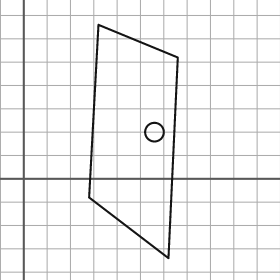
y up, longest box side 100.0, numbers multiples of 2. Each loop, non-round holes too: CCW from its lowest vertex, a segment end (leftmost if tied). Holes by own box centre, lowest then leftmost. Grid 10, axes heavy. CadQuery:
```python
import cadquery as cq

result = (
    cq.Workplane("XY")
    .moveTo(62.0, -34.0)
    .lineTo(66.0, 52.0)
    .lineTo(32.0, 66.0)
    .lineTo(28.0, -8.0)
    .close()
    .moveTo(56.0, 20.0)
    .circle(4.0)
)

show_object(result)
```